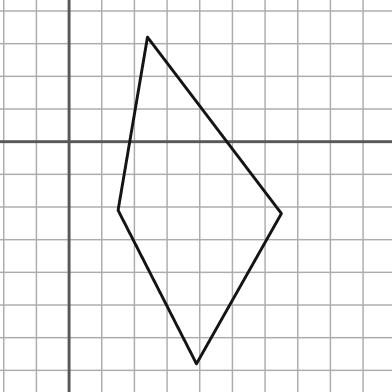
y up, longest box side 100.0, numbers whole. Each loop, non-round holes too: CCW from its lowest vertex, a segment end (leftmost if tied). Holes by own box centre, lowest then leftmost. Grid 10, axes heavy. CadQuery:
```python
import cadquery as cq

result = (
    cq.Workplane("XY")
    .moveTo(39.0, -68.0)
    .lineTo(65.0, -22.0)
    .lineTo(24.0, 32.0)
    .lineTo(15.0, -21.0)
    .close()
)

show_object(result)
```